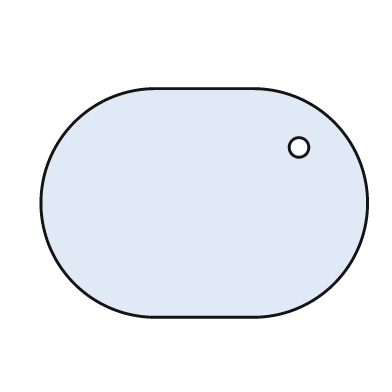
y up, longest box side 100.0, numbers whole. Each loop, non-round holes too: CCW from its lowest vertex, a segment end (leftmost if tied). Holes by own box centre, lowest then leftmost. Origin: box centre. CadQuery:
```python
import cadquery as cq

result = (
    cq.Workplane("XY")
    .moveTo(-15.0, -35.0)
    .lineTo(15.0, -35.0)
    .threePointArc((50.0, 0.0), (15.0, 35.0))
    .lineTo(-15.0, 35.0)
    .threePointArc((-50.0, 0.0), (-15.0, -35.0))
    .close()
    .moveTo(29.0, 17.0)
    .circle(3.0)
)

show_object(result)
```